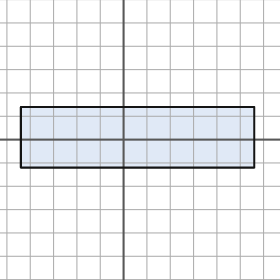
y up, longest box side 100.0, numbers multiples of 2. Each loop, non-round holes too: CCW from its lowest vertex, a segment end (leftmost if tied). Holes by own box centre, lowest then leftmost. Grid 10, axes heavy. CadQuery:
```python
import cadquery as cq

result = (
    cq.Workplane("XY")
    .moveTo(-44.0, -12.0)
    .lineTo(56.0, -12.0)
    .lineTo(56.0, 14.0)
    .lineTo(-44.0, 14.0)
    .close()
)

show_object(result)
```